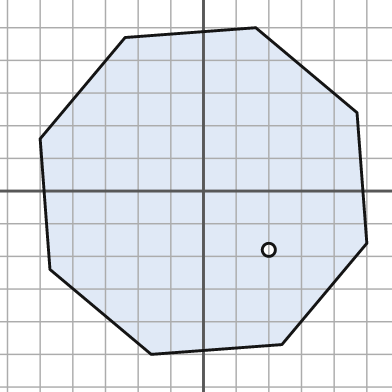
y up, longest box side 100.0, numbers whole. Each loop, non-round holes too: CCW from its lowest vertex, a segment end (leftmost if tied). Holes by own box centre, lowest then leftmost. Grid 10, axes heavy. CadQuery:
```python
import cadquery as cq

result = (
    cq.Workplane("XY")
    .moveTo(-16.0, -50.0)
    .lineTo(24.0, -47.0)
    .lineTo(50.0, -16.0)
    .lineTo(47.0, 24.0)
    .lineTo(16.0, 50.0)
    .lineTo(-24.0, 47.0)
    .lineTo(-50.0, 16.0)
    .lineTo(-47.0, -24.0)
    .close()
    .moveTo(20.0, -18.0)
    .circle(2.0)
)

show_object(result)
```